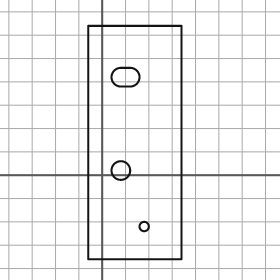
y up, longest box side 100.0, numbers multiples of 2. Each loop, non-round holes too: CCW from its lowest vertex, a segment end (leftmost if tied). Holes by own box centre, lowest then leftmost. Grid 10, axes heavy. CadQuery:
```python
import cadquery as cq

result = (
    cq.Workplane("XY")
    .moveTo(-6.0, -36.0)
    .lineTo(34.0, -36.0)
    .lineTo(34.0, 64.0)
    .lineTo(-6.0, 64.0)
    .close()
    .moveTo(18.0, -22.0)
    .circle(2.0)
    .moveTo(8.0, 2.0)
    .circle(4.0)
    .moveTo(8.0, 38.0)
    .lineTo(12.0, 38.0)
    .threePointArc((16.0, 42.0), (12.0, 46.0))
    .lineTo(8.0, 46.0)
    .threePointArc((4.0, 42.0), (8.0, 38.0))
    .close()
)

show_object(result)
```